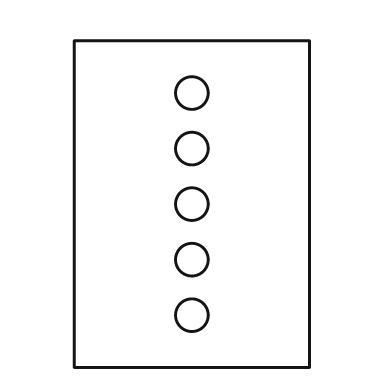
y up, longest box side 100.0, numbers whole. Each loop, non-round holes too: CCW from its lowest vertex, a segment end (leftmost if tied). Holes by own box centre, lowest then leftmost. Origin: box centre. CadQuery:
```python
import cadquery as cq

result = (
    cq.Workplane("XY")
    .moveTo(-36.0, -50.0)
    .lineTo(36.0, -50.0)
    .lineTo(36.0, 50.0)
    .lineTo(-36.0, 50.0)
    .close()
    .moveTo(0.0, -34.0)
    .circle(5.0)
    .moveTo(0.0, -17.0)
    .circle(5.0)
    .moveTo(0.0, 0.0)
    .circle(5.0)
    .moveTo(0.0, 17.0)
    .circle(5.0)
    .moveTo(0.0, 34.0)
    .circle(5.0)
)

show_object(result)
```